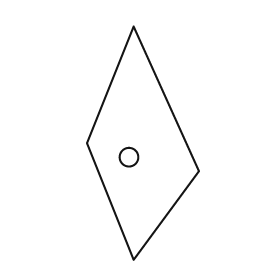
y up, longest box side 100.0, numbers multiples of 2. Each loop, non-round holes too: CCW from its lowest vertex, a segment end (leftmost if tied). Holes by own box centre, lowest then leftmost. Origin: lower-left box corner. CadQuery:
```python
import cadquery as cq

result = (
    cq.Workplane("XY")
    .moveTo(20.0, 0.0)
    .lineTo(48.0, 38.0)
    .lineTo(20.0, 100.0)
    .lineTo(0.0, 50.0)
    .close()
    .moveTo(18.0, 44.0)
    .circle(4.0)
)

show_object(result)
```